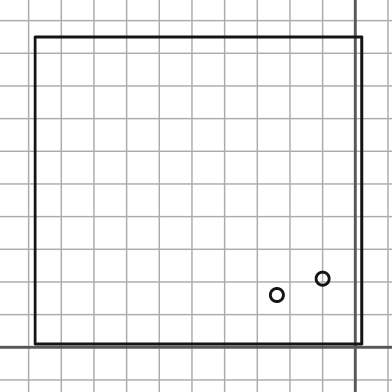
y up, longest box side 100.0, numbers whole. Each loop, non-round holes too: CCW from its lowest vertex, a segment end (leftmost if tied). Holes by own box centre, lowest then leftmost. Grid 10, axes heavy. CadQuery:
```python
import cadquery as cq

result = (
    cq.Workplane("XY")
    .moveTo(-98.0, 1.0)
    .lineTo(2.0, 1.0)
    .lineTo(2.0, 95.0)
    .lineTo(-98.0, 95.0)
    .close()
    .moveTo(-24.0, 16.0)
    .circle(2.0)
    .moveTo(-10.0, 21.0)
    .circle(2.0)
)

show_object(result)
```